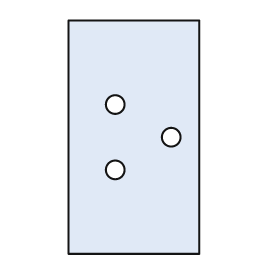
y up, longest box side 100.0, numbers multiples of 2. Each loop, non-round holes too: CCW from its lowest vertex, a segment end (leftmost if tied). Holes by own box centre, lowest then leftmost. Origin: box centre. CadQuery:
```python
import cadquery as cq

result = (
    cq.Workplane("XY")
    .moveTo(-28.0, -50.0)
    .lineTo(28.0, -50.0)
    .lineTo(28.0, 50.0)
    .lineTo(-28.0, 50.0)
    .close()
    .moveTo(-8.0, -14.0)
    .circle(4.0)
    .moveTo(16.0, 0.0)
    .circle(4.0)
    .moveTo(-8.0, 14.0)
    .circle(4.0)
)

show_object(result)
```